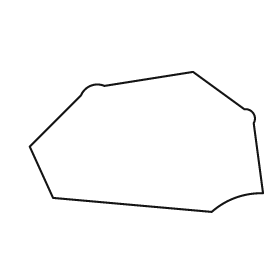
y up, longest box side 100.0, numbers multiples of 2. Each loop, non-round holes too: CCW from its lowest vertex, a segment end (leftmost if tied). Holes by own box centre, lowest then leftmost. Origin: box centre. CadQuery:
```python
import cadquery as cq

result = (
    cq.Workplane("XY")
    .moveTo(28.0, -30.0)
    .threePointArc((38.0, -24.0), (50.0, -22.0))
    .lineTo(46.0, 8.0)
    .threePointArc((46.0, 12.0), (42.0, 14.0))
    .lineTo(20.0, 30.0)
    .lineTo(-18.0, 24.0)
    .threePointArc((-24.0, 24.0), (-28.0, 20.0))
    .lineTo(-50.0, -2.0)
    .lineTo(-40.0, -24.0)
    .close()
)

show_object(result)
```